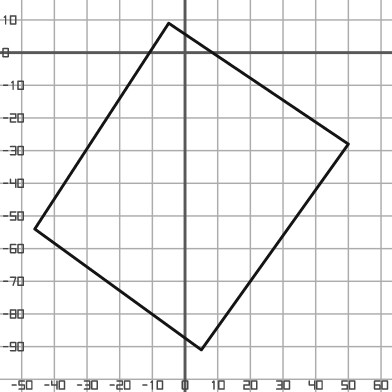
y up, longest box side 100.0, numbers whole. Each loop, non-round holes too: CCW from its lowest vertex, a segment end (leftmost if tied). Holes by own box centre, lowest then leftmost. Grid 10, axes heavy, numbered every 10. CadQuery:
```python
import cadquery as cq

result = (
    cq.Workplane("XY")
    .moveTo(5.0, -91.0)
    .lineTo(50.0, -28.0)
    .lineTo(-5.0, 9.0)
    .lineTo(-46.0, -54.0)
    .close()
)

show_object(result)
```